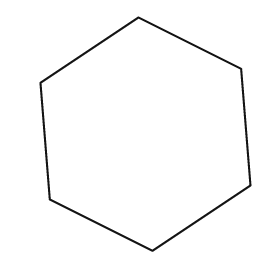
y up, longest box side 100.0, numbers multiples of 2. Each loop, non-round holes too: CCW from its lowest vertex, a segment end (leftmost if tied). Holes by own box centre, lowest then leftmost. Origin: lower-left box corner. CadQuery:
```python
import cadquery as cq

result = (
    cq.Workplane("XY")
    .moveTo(48.0, 0.0)
    .lineTo(90.0, 28.0)
    .lineTo(86.0, 78.0)
    .lineTo(42.0, 100.0)
    .lineTo(0.0, 72.0)
    .lineTo(4.0, 22.0)
    .close()
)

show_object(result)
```